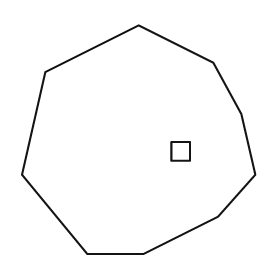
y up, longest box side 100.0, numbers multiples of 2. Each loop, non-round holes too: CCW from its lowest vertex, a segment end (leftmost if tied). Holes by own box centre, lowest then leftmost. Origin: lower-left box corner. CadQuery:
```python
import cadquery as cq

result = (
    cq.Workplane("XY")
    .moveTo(28.0, 0.0)
    .lineTo(52.0, 0.0)
    .lineTo(84.0, 16.0)
    .lineTo(100.0, 34.0)
    .lineTo(94.0, 60.0)
    .lineTo(82.0, 82.0)
    .lineTo(50.0, 98.0)
    .lineTo(10.0, 78.0)
    .lineTo(0.0, 34.0)
    .close()
    .moveTo(64.0, 40.0)
    .lineTo(72.0, 40.0)
    .lineTo(72.0, 48.0)
    .lineTo(64.0, 48.0)
    .close()
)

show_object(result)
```